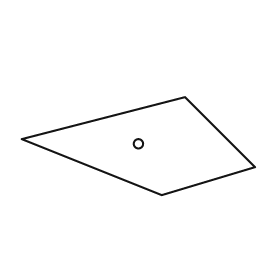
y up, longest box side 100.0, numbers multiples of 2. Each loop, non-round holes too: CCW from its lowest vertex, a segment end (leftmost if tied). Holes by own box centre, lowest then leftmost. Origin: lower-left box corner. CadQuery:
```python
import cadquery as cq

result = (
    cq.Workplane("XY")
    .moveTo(60.0, 0.0)
    .lineTo(100.0, 12.0)
    .lineTo(70.0, 42.0)
    .lineTo(0.0, 24.0)
    .close()
    .moveTo(50.0, 22.0)
    .circle(2.0)
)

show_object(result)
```